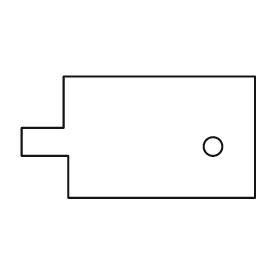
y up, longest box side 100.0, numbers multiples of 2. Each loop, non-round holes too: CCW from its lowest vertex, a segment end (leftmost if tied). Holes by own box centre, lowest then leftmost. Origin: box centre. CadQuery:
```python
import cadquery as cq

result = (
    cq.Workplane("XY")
    .moveTo(-30.0, -26.0)
    .lineTo(50.0, -26.0)
    .lineTo(50.0, 26.0)
    .lineTo(-32.0, 26.0)
    .lineTo(-32.0, 4.0)
    .lineTo(-50.0, 4.0)
    .lineTo(-50.0, -8.0)
    .lineTo(-30.0, -8.0)
    .close()
    .moveTo(32.0, -4.0)
    .circle(4.0)
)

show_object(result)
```